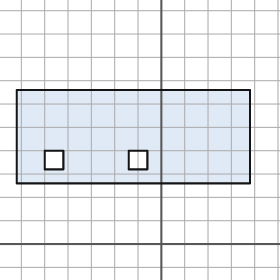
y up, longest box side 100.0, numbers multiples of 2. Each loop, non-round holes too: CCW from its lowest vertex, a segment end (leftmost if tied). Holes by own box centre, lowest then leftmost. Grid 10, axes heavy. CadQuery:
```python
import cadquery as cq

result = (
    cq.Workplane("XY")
    .moveTo(-62.0, 26.0)
    .lineTo(38.0, 26.0)
    .lineTo(38.0, 66.0)
    .lineTo(-62.0, 66.0)
    .close()
    .moveTo(-50.0, 32.0)
    .lineTo(-42.0, 32.0)
    .lineTo(-42.0, 40.0)
    .lineTo(-50.0, 40.0)
    .close()
    .moveTo(-14.0, 32.0)
    .lineTo(-6.0, 32.0)
    .lineTo(-6.0, 40.0)
    .lineTo(-14.0, 40.0)
    .close()
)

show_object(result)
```